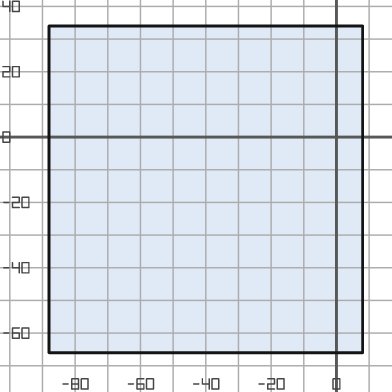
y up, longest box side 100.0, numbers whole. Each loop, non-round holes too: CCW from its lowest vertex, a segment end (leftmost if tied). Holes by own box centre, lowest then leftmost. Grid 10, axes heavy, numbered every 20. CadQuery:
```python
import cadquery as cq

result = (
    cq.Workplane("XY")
    .moveTo(-88.0, -66.0)
    .lineTo(8.0, -66.0)
    .lineTo(8.0, 34.0)
    .lineTo(-88.0, 34.0)
    .close()
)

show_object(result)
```